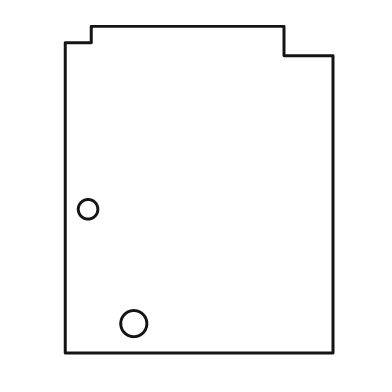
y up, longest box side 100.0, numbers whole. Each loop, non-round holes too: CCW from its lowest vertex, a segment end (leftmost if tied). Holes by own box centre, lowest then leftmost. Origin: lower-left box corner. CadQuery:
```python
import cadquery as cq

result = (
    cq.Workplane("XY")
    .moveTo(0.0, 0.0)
    .lineTo(82.0, 0.0)
    .lineTo(82.0, 91.0)
    .lineTo(67.0, 91.0)
    .lineTo(67.0, 100.0)
    .lineTo(8.0, 100.0)
    .lineTo(8.0, 95.0)
    .lineTo(0.0, 95.0)
    .close()
    .moveTo(21.0, 9.0)
    .circle(4.0)
    .moveTo(7.0, 44.0)
    .circle(3.0)
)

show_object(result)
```